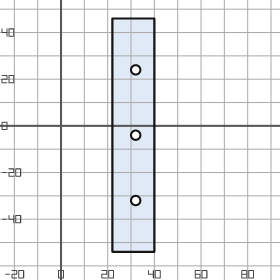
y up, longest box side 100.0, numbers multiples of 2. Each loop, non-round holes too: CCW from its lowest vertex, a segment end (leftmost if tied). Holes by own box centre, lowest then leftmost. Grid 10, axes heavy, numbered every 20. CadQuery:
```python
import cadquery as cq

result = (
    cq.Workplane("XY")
    .moveTo(22.0, -54.0)
    .lineTo(40.0, -54.0)
    .lineTo(40.0, 46.0)
    .lineTo(22.0, 46.0)
    .close()
    .moveTo(32.0, -32.0)
    .circle(2.0)
    .moveTo(32.0, -4.0)
    .circle(2.0)
    .moveTo(32.0, 24.0)
    .circle(2.0)
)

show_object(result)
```